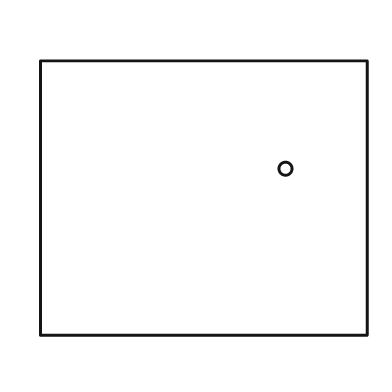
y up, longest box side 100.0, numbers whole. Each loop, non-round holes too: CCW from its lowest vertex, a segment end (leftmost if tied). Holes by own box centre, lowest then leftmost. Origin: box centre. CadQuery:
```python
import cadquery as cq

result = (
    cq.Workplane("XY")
    .moveTo(-50.0, -42.0)
    .lineTo(50.0, -42.0)
    .lineTo(50.0, 42.0)
    .lineTo(-50.0, 42.0)
    .close()
    .moveTo(25.0, 9.0)
    .circle(2.0)
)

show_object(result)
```